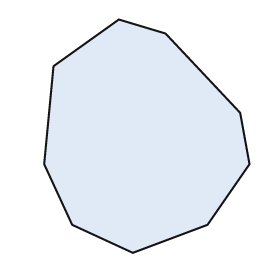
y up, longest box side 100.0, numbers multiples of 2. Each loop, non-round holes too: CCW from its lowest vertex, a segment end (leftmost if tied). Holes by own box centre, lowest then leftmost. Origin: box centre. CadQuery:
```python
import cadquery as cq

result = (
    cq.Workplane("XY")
    .moveTo(-6.0, -50.0)
    .lineTo(26.0, -38.0)
    .lineTo(44.0, -12.0)
    .lineTo(40.0, 10.0)
    .lineTo(8.0, 44.0)
    .lineTo(-12.0, 50.0)
    .lineTo(-40.0, 30.0)
    .lineTo(-44.0, -12.0)
    .lineTo(-32.0, -38.0)
    .close()
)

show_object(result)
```